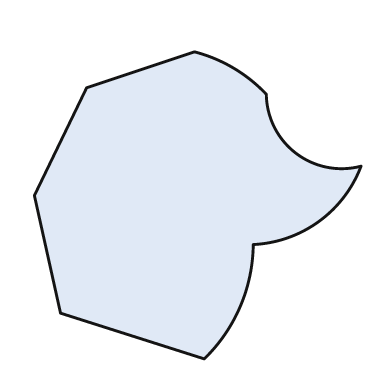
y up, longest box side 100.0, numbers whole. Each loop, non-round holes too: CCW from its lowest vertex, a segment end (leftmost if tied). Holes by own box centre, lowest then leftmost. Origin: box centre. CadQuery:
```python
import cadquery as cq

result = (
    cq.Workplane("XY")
    .moveTo(2.0, -47.0)
    .threePointArc((13.0, -31.0), (17.0, -12.0))
    .threePointArc((37.0, -5.0), (50.0, 12.0))
    .threePointArc((30.0, 16.0), (21.0, 34.0))
    .threePointArc((11.0, 42.0), (-1.0, 47.0))
    .lineTo(-34.0, 36.0)
    .lineTo(-50.0, 3.0)
    .lineTo(-42.0, -33.0)
    .close()
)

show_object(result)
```